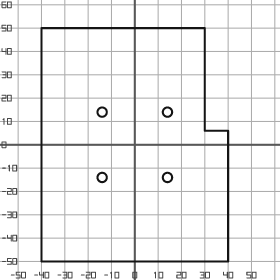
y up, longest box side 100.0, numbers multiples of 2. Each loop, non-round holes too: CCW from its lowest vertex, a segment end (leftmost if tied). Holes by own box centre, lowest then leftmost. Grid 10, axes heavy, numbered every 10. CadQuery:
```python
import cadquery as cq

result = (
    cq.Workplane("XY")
    .moveTo(-40.0, -50.0)
    .lineTo(40.0, -50.0)
    .lineTo(40.0, 6.0)
    .lineTo(30.0, 6.0)
    .lineTo(30.0, 50.0)
    .lineTo(-40.0, 50.0)
    .close()
    .moveTo(-14.0, -14.0)
    .circle(2.0)
    .moveTo(14.0, -14.0)
    .circle(2.0)
    .moveTo(-14.0, 14.0)
    .circle(2.0)
    .moveTo(14.0, 14.0)
    .circle(2.0)
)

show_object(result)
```